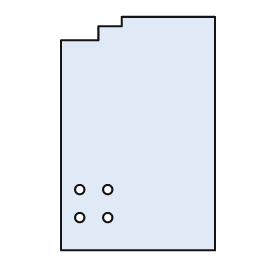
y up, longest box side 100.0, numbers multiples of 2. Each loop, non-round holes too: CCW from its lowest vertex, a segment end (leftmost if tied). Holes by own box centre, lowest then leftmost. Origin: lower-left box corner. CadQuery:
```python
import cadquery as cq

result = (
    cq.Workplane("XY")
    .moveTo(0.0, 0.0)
    .lineTo(66.0, 0.0)
    .lineTo(66.0, 100.0)
    .lineTo(26.0, 100.0)
    .lineTo(26.0, 96.0)
    .lineTo(16.0, 96.0)
    .lineTo(16.0, 90.0)
    .lineTo(0.0, 90.0)
    .close()
    .moveTo(8.0, 14.0)
    .circle(2.0)
    .moveTo(20.0, 14.0)
    .circle(2.0)
    .moveTo(8.0, 26.0)
    .circle(2.0)
    .moveTo(20.0, 26.0)
    .circle(2.0)
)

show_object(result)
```